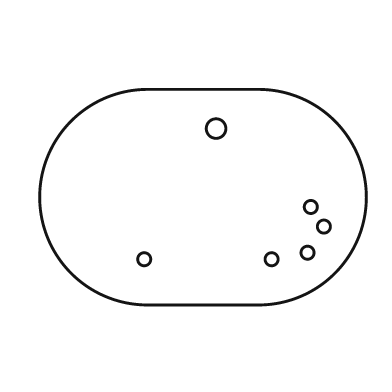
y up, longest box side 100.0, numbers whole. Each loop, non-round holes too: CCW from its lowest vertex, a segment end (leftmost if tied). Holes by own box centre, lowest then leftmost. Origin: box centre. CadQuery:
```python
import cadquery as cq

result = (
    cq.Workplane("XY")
    .moveTo(-17.0, -33.0)
    .lineTo(17.0, -33.0)
    .threePointArc((50.0, 0.0), (17.0, 33.0))
    .lineTo(-17.0, 33.0)
    .threePointArc((-50.0, 0.0), (-17.0, -33.0))
    .close()
    .moveTo(-18.0, -19.0)
    .circle(2.0)
    .moveTo(21.0, -19.0)
    .circle(2.0)
    .moveTo(32.0, -17.0)
    .circle(2.0)
    .moveTo(37.0, -9.0)
    .circle(2.0)
    .moveTo(33.0, -3.0)
    .circle(2.0)
    .moveTo(4.0, 21.0)
    .circle(3.0)
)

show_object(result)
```